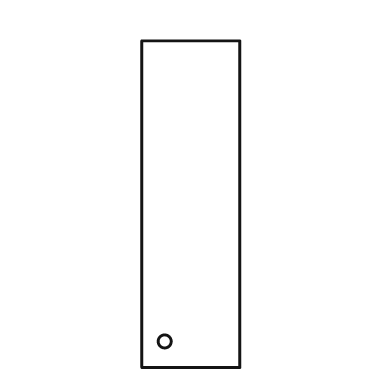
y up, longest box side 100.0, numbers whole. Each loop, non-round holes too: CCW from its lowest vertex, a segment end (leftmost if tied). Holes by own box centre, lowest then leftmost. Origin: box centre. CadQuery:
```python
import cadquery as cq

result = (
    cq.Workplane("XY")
    .moveTo(-15.0, -50.0)
    .lineTo(15.0, -50.0)
    .lineTo(15.0, 50.0)
    .lineTo(-15.0, 50.0)
    .close()
    .moveTo(-8.0, -42.0)
    .circle(2.0)
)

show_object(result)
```